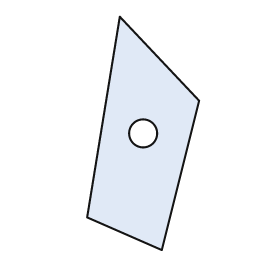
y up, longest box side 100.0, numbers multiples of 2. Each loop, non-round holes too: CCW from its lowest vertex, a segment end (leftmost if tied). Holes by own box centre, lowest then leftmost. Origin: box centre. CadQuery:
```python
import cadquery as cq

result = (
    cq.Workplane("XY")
    .moveTo(8.0, -50.0)
    .lineTo(24.0, 14.0)
    .lineTo(-10.0, 50.0)
    .lineTo(-24.0, -36.0)
    .close()
    .moveTo(0.0, 0.0)
    .circle(6.0)
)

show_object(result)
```